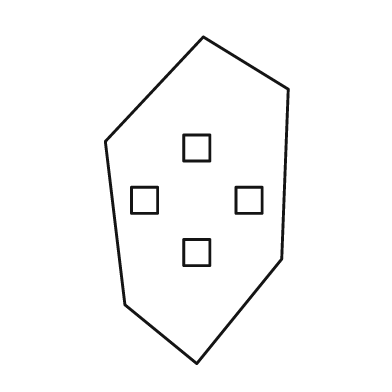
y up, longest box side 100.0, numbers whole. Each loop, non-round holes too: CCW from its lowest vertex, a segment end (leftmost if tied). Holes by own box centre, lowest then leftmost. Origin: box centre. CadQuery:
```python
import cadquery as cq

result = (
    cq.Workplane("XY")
    .moveTo(0.0, -50.0)
    .lineTo(26.0, -18.0)
    .lineTo(28.0, 34.0)
    .lineTo(2.0, 50.0)
    .lineTo(-28.0, 18.0)
    .lineTo(-22.0, -32.0)
    .close()
    .moveTo(-4.0, -20.0)
    .lineTo(4.0, -20.0)
    .lineTo(4.0, -12.0)
    .lineTo(-4.0, -12.0)
    .close()
    .moveTo(-20.0, -4.0)
    .lineTo(-12.0, -4.0)
    .lineTo(-12.0, 4.0)
    .lineTo(-20.0, 4.0)
    .close()
    .moveTo(12.0, -4.0)
    .lineTo(20.0, -4.0)
    .lineTo(20.0, 4.0)
    .lineTo(12.0, 4.0)
    .close()
    .moveTo(-4.0, 12.0)
    .lineTo(4.0, 12.0)
    .lineTo(4.0, 20.0)
    .lineTo(-4.0, 20.0)
    .close()
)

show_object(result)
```